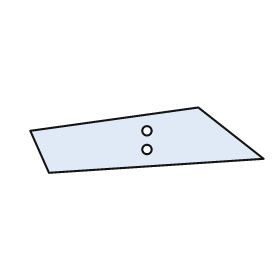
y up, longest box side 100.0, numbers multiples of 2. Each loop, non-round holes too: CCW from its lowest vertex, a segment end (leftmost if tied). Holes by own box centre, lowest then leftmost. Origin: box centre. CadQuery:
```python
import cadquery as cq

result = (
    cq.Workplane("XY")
    .moveTo(-42.0, -14.0)
    .lineTo(50.0, -8.0)
    .lineTo(22.0, 14.0)
    .lineTo(-50.0, 4.0)
    .close()
    .moveTo(0.0, -4.0)
    .circle(2.0)
    .moveTo(0.0, 4.0)
    .circle(2.0)
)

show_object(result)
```